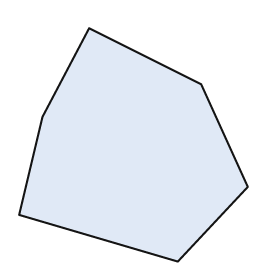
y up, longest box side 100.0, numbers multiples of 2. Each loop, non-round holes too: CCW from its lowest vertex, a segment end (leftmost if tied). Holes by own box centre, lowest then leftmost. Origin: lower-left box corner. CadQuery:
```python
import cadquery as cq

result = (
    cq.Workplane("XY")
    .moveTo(68.0, 0.0)
    .lineTo(98.0, 32.0)
    .lineTo(78.0, 76.0)
    .lineTo(30.0, 100.0)
    .lineTo(10.0, 62.0)
    .lineTo(0.0, 20.0)
    .close()
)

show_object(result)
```